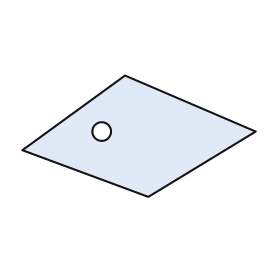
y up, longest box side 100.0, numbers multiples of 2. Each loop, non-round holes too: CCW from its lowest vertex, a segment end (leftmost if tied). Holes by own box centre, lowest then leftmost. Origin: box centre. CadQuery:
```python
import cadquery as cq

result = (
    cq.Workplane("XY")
    .moveTo(4.0, -26.0)
    .lineTo(50.0, 2.0)
    .lineTo(-6.0, 26.0)
    .lineTo(-50.0, -6.0)
    .close()
    .moveTo(-16.0, 2.0)
    .circle(4.0)
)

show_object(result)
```